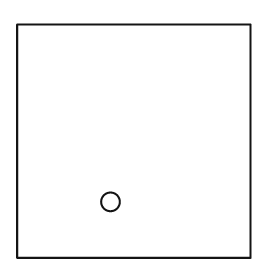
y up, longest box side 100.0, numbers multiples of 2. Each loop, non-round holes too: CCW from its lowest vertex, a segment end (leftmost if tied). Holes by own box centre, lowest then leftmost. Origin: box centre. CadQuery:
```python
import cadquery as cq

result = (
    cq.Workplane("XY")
    .moveTo(-50.0, -50.0)
    .lineTo(50.0, -50.0)
    .lineTo(50.0, 50.0)
    .lineTo(-50.0, 50.0)
    .close()
    .moveTo(-10.0, -26.0)
    .circle(4.0)
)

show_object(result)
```